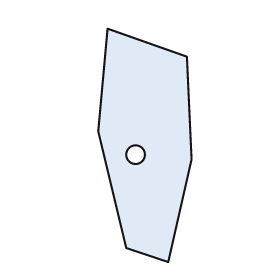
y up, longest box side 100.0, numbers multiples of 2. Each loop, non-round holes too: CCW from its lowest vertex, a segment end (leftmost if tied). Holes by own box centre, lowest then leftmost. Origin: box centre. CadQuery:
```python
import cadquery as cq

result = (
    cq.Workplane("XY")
    .moveTo(10.0, -50.0)
    .lineTo(20.0, -6.0)
    .lineTo(18.0, 38.0)
    .lineTo(-16.0, 50.0)
    .lineTo(-20.0, 6.0)
    .lineTo(-8.0, -44.0)
    .close()
    .moveTo(-4.0, -4.0)
    .circle(4.0)
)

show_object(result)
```